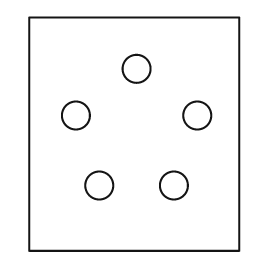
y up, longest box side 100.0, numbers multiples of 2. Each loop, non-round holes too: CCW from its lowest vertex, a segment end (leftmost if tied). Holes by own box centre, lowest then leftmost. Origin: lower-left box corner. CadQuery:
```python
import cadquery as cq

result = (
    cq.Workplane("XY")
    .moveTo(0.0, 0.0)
    .lineTo(90.0, 0.0)
    .lineTo(90.0, 100.0)
    .lineTo(0.0, 100.0)
    .close()
    .moveTo(30.0, 28.0)
    .circle(6.0)
    .moveTo(62.0, 28.0)
    .circle(6.0)
    .moveTo(20.0, 58.0)
    .circle(6.0)
    .moveTo(72.0, 58.0)
    .circle(6.0)
    .moveTo(46.0, 78.0)
    .circle(6.0)
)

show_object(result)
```